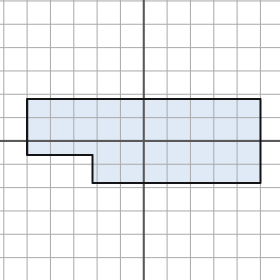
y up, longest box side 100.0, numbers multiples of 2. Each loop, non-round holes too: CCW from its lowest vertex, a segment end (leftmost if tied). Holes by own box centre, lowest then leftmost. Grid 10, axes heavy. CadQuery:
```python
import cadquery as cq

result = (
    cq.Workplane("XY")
    .moveTo(-22.0, -18.0)
    .lineTo(50.0, -18.0)
    .lineTo(50.0, 18.0)
    .lineTo(-50.0, 18.0)
    .lineTo(-50.0, -6.0)
    .lineTo(-22.0, -6.0)
    .close()
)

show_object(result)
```